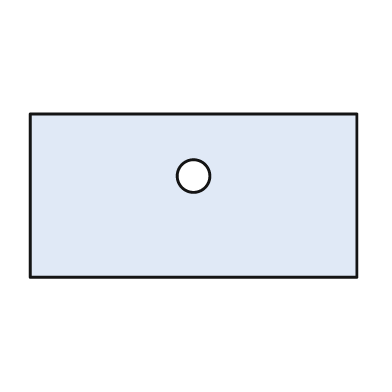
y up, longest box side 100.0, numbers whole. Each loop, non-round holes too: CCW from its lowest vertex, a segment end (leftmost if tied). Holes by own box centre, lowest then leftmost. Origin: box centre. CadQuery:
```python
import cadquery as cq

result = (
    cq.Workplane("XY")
    .moveTo(-50.0, -25.0)
    .lineTo(50.0, -25.0)
    .lineTo(50.0, 25.0)
    .lineTo(-50.0, 25.0)
    .close()
    .moveTo(0.0, 6.0)
    .circle(5.0)
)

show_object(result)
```